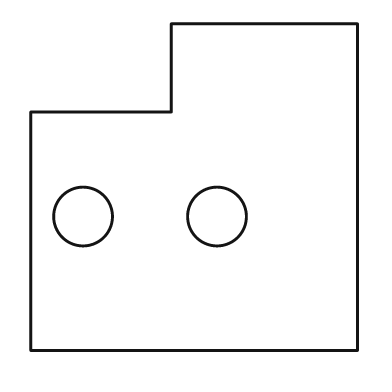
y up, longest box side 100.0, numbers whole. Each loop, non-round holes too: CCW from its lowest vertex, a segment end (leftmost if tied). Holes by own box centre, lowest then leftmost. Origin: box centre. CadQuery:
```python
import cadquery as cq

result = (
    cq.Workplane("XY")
    .moveTo(-50.0, -50.0)
    .lineTo(50.0, -50.0)
    .lineTo(50.0, 50.0)
    .lineTo(-7.0, 50.0)
    .lineTo(-7.0, 23.0)
    .lineTo(-50.0, 23.0)
    .close()
    .moveTo(-34.0, -9.0)
    .circle(9.0)
    .moveTo(7.0, -9.0)
    .circle(9.0)
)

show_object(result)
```